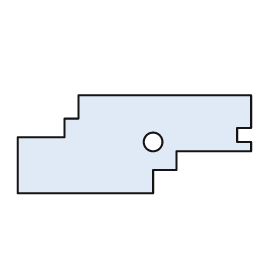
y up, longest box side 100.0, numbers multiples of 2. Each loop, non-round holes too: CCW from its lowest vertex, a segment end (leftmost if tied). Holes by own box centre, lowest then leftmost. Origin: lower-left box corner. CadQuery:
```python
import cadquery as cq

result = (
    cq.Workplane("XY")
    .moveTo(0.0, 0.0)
    .lineTo(58.0, 0.0)
    .lineTo(58.0, 10.0)
    .lineTo(68.0, 10.0)
    .lineTo(68.0, 18.0)
    .lineTo(100.0, 18.0)
    .lineTo(100.0, 22.0)
    .lineTo(94.0, 22.0)
    .lineTo(94.0, 28.0)
    .lineTo(100.0, 28.0)
    .lineTo(100.0, 42.0)
    .lineTo(26.0, 42.0)
    .lineTo(26.0, 32.0)
    .lineTo(20.0, 32.0)
    .lineTo(20.0, 24.0)
    .lineTo(0.0, 24.0)
    .close()
    .moveTo(58.0, 22.0)
    .circle(4.0)
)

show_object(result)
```